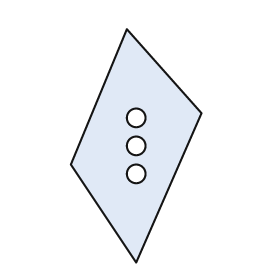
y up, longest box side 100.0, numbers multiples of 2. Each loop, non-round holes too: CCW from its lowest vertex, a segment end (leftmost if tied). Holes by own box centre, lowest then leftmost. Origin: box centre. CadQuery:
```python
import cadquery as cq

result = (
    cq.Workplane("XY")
    .moveTo(0.0, -50.0)
    .lineTo(28.0, 14.0)
    .lineTo(-4.0, 50.0)
    .lineTo(-28.0, -8.0)
    .close()
    .moveTo(0.0, -12.0)
    .circle(4.0)
    .moveTo(0.0, 0.0)
    .circle(4.0)
    .moveTo(0.0, 12.0)
    .circle(4.0)
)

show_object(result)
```